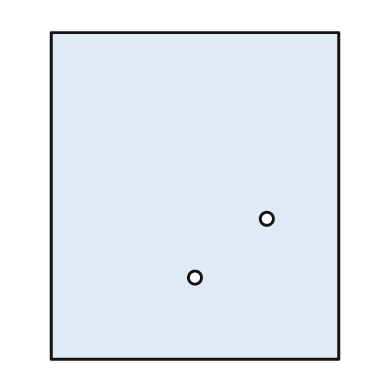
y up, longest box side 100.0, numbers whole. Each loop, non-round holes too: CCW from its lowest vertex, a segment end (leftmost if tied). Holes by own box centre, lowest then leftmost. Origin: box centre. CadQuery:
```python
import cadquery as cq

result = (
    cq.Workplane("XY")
    .moveTo(-44.0, -50.0)
    .lineTo(44.0, -50.0)
    .lineTo(44.0, 50.0)
    .lineTo(-44.0, 50.0)
    .close()
    .moveTo(0.0, -25.0)
    .circle(2.0)
    .moveTo(22.0, -7.0)
    .circle(2.0)
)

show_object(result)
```